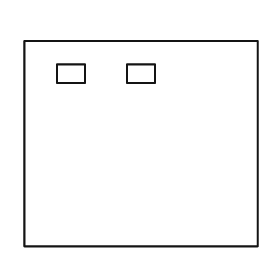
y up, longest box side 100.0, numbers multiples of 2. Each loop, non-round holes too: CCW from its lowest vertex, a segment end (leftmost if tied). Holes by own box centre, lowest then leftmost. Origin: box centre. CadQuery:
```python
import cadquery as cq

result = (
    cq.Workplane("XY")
    .moveTo(-50.0, -44.0)
    .lineTo(50.0, -44.0)
    .lineTo(50.0, 44.0)
    .lineTo(-50.0, 44.0)
    .close()
    .moveTo(-36.0, 26.0)
    .lineTo(-24.0, 26.0)
    .lineTo(-24.0, 34.0)
    .lineTo(-36.0, 34.0)
    .close()
    .moveTo(-6.0, 26.0)
    .lineTo(6.0, 26.0)
    .lineTo(6.0, 34.0)
    .lineTo(-6.0, 34.0)
    .close()
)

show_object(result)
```